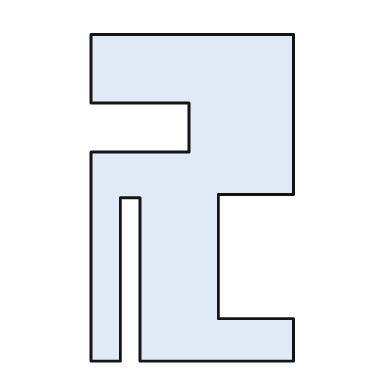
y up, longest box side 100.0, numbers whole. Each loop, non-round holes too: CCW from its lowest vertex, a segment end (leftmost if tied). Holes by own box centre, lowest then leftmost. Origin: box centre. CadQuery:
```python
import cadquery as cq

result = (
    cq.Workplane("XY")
    .moveTo(-31.0, -50.0)
    .lineTo(-22.0, -50.0)
    .lineTo(-22.0, 0.0)
    .lineTo(-16.0, 0.0)
    .lineTo(-16.0, -50.0)
    .lineTo(31.0, -50.0)
    .lineTo(31.0, -37.0)
    .lineTo(8.0, -37.0)
    .lineTo(8.0, 1.0)
    .lineTo(31.0, 1.0)
    .lineTo(31.0, 50.0)
    .lineTo(-31.0, 50.0)
    .lineTo(-31.0, 29.0)
    .lineTo(-1.0, 29.0)
    .lineTo(-1.0, 14.0)
    .lineTo(-31.0, 14.0)
    .close()
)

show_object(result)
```